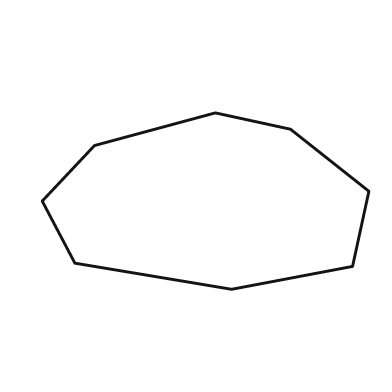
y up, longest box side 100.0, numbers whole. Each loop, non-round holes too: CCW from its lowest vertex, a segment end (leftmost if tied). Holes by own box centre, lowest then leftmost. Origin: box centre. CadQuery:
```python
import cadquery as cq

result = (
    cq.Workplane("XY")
    .moveTo(8.0, -27.0)
    .lineTo(45.0, -20.0)
    .lineTo(50.0, 3.0)
    .lineTo(26.0, 22.0)
    .lineTo(3.0, 27.0)
    .lineTo(-34.0, 17.0)
    .lineTo(-50.0, 0.0)
    .lineTo(-40.0, -19.0)
    .close()
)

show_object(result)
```